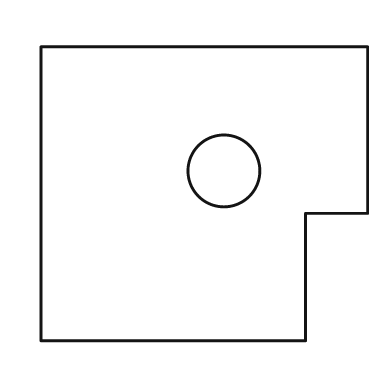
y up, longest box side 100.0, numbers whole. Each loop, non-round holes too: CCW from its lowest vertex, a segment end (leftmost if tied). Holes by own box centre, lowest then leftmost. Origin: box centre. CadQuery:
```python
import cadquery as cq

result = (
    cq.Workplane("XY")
    .moveTo(-50.0, -45.0)
    .lineTo(31.0, -45.0)
    .lineTo(31.0, -6.0)
    .lineTo(50.0, -6.0)
    .lineTo(50.0, 45.0)
    .lineTo(-50.0, 45.0)
    .close()
    .moveTo(6.0, 7.0)
    .circle(11.0)
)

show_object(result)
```